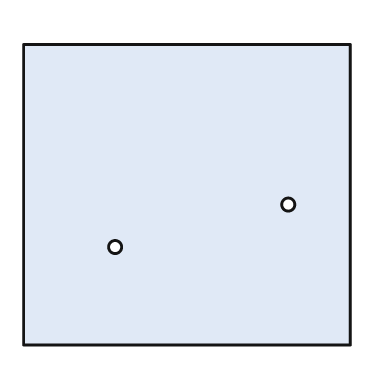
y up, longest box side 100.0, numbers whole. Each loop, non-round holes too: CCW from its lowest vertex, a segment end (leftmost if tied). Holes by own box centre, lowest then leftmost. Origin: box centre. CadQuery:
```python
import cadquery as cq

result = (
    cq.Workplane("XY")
    .moveTo(-50.0, -46.0)
    .lineTo(50.0, -46.0)
    .lineTo(50.0, 46.0)
    .lineTo(-50.0, 46.0)
    .close()
    .moveTo(-22.0, -16.0)
    .circle(2.0)
    .moveTo(31.0, -3.0)
    .circle(2.0)
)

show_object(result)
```